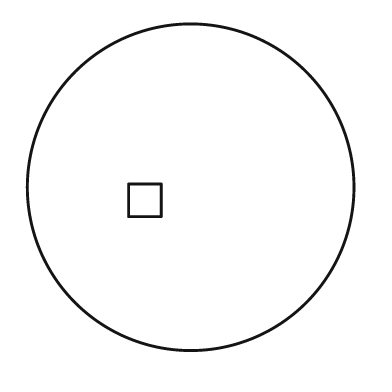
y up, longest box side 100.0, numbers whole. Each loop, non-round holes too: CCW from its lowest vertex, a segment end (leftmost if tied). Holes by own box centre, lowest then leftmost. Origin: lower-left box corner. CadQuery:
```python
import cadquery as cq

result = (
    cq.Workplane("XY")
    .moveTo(50.0, 50.0)
    .circle(50.0)
    .moveTo(31.0, 41.0)
    .lineTo(41.0, 41.0)
    .lineTo(41.0, 51.0)
    .lineTo(31.0, 51.0)
    .close()
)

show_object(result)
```